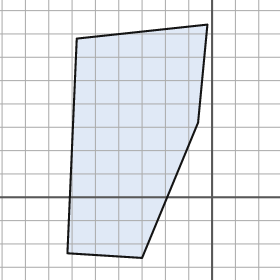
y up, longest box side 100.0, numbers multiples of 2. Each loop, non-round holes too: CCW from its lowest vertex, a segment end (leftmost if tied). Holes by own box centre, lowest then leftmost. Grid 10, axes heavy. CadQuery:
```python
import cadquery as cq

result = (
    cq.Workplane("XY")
    .moveTo(-30.0, -26.0)
    .lineTo(-6.0, 32.0)
    .lineTo(-2.0, 74.0)
    .lineTo(-58.0, 68.0)
    .lineTo(-62.0, -24.0)
    .close()
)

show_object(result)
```